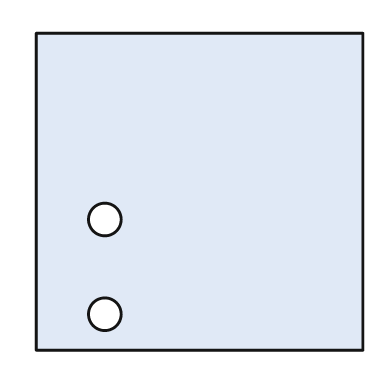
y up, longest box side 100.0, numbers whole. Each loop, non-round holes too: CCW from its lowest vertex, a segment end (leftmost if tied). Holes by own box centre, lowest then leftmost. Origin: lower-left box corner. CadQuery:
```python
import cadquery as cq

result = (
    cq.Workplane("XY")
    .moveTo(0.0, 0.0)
    .lineTo(100.0, 0.0)
    .lineTo(100.0, 97.0)
    .lineTo(0.0, 97.0)
    .close()
    .moveTo(21.0, 11.0)
    .circle(5.0)
    .moveTo(21.0, 40.0)
    .circle(5.0)
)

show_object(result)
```